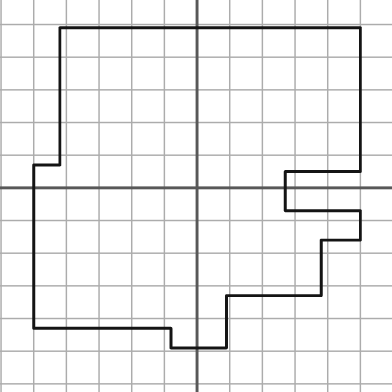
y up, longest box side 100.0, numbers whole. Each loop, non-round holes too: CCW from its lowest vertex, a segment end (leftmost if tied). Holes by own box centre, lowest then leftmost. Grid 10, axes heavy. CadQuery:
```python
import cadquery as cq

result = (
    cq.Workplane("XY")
    .moveTo(-8.0, -49.0)
    .lineTo(9.0, -49.0)
    .lineTo(9.0, -33.0)
    .lineTo(38.0, -33.0)
    .lineTo(38.0, -16.0)
    .lineTo(50.0, -16.0)
    .lineTo(50.0, -7.0)
    .lineTo(27.0, -7.0)
    .lineTo(27.0, 5.0)
    .lineTo(50.0, 5.0)
    .lineTo(50.0, 49.0)
    .lineTo(-42.0, 49.0)
    .lineTo(-42.0, 7.0)
    .lineTo(-50.0, 7.0)
    .lineTo(-50.0, -43.0)
    .lineTo(-8.0, -43.0)
    .close()
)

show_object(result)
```